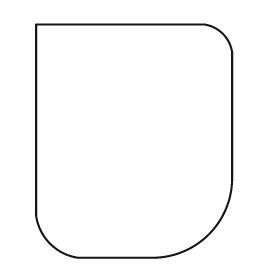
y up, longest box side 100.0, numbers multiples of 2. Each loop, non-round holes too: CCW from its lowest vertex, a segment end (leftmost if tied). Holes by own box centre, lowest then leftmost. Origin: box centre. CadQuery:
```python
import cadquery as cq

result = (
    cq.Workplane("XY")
    .moveTo(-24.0, -50.0)
    .lineTo(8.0, -50.0)
    .threePointArc((32.0, -40.0), (42.0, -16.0))
    .lineTo(42.0, 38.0)
    .threePointArc((38.0, 46.0), (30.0, 50.0))
    .lineTo(-42.0, 50.0)
    .lineTo(-42.0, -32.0)
    .threePointArc((-36.0, -44.0), (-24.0, -50.0))
    .close()
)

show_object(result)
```